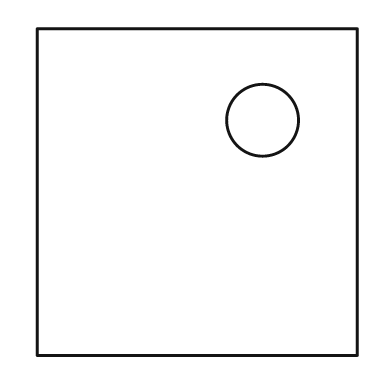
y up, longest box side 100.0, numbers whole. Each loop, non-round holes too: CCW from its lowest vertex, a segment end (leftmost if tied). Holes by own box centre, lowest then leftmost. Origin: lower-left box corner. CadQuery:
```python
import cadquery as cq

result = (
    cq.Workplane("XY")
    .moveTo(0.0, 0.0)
    .lineTo(98.0, 0.0)
    .lineTo(98.0, 100.0)
    .lineTo(0.0, 100.0)
    .close()
    .moveTo(69.0, 72.0)
    .circle(11.0)
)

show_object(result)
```